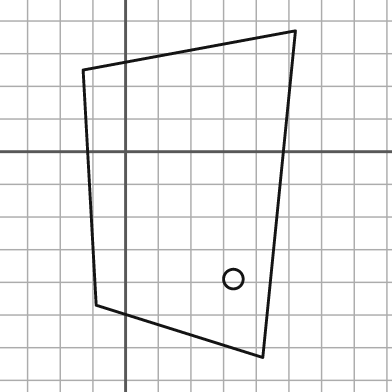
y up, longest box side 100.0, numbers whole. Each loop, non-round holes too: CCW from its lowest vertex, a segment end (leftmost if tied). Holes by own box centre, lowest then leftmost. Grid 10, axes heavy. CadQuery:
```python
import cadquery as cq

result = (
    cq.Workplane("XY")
    .moveTo(42.0, -63.0)
    .lineTo(52.0, 37.0)
    .lineTo(-13.0, 25.0)
    .lineTo(-9.0, -47.0)
    .close()
    .moveTo(33.0, -39.0)
    .circle(3.0)
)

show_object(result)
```